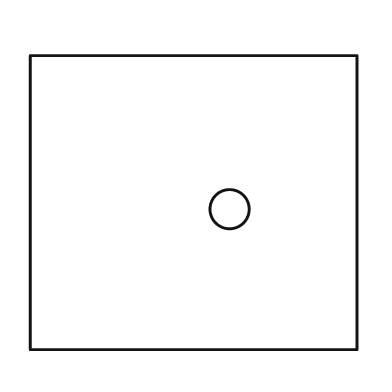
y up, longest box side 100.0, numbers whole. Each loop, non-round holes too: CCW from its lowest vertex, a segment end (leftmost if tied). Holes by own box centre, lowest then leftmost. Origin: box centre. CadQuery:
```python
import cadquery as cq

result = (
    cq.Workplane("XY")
    .moveTo(-50.0, -45.0)
    .lineTo(50.0, -45.0)
    .lineTo(50.0, 45.0)
    .lineTo(-50.0, 45.0)
    .close()
    .moveTo(11.0, -2.0)
    .circle(6.0)
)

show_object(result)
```